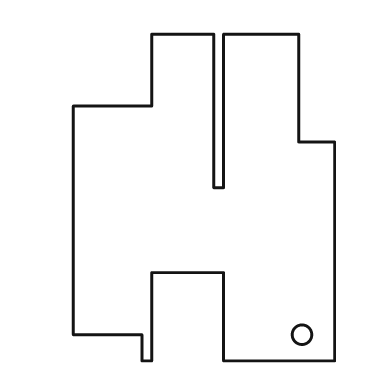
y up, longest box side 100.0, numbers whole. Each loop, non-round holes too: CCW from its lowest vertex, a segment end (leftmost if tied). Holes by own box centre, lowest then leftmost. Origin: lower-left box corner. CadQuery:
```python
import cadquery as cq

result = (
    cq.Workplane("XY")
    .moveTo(21.0, 0.0)
    .lineTo(24.0, 0.0)
    .lineTo(24.0, 27.0)
    .lineTo(46.0, 27.0)
    .lineTo(46.0, 0.0)
    .lineTo(80.0, 0.0)
    .lineTo(80.0, 67.0)
    .lineTo(69.0, 67.0)
    .lineTo(69.0, 100.0)
    .lineTo(46.0, 100.0)
    .lineTo(46.0, 53.0)
    .lineTo(43.0, 53.0)
    .lineTo(43.0, 100.0)
    .lineTo(24.0, 100.0)
    .lineTo(24.0, 78.0)
    .lineTo(0.0, 78.0)
    .lineTo(0.0, 8.0)
    .lineTo(21.0, 8.0)
    .close()
    .moveTo(70.0, 8.0)
    .circle(3.0)
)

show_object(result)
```